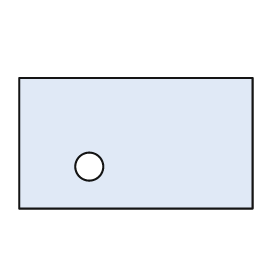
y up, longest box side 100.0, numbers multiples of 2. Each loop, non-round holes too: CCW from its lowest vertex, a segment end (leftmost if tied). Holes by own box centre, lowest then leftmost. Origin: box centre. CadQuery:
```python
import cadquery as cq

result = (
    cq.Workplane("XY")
    .moveTo(-50.0, -28.0)
    .lineTo(50.0, -28.0)
    .lineTo(50.0, 28.0)
    .lineTo(-50.0, 28.0)
    .close()
    .moveTo(-20.0, -10.0)
    .circle(6.0)
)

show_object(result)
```